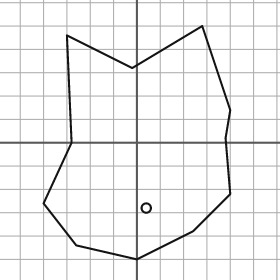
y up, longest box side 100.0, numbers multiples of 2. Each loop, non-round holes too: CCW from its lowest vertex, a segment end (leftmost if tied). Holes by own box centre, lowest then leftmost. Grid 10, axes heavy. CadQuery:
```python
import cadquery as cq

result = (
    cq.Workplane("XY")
    .moveTo(0.0, -50.0)
    .lineTo(24.0, -38.0)
    .lineTo(40.0, -22.0)
    .lineTo(38.0, 2.0)
    .lineTo(40.0, 14.0)
    .lineTo(28.0, 50.0)
    .lineTo(-2.0, 32.0)
    .lineTo(-30.0, 46.0)
    .lineTo(-28.0, 0.0)
    .lineTo(-40.0, -26.0)
    .lineTo(-26.0, -44.0)
    .close()
    .moveTo(4.0, -28.0)
    .circle(2.0)
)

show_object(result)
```